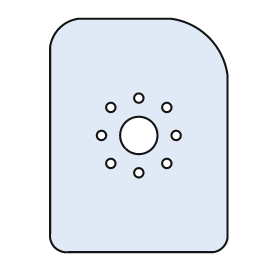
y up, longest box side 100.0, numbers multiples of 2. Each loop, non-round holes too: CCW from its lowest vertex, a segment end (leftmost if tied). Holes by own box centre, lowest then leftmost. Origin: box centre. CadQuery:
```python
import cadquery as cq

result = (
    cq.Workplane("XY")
    .moveTo(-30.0, -50.0)
    .lineTo(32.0, -50.0)
    .threePointArc((36.0, -48.0), (38.0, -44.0))
    .lineTo(38.0, 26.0)
    .threePointArc((30.0, 42.0), (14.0, 50.0))
    .lineTo(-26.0, 50.0)
    .threePointArc((-34.0, 46.0), (-38.0, 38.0))
    .lineTo(-38.0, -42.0)
    .threePointArc((-36.0, -48.0), (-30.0, -50.0))
    .close()
    .moveTo(0.0, -16.0)
    .circle(2.0)
    .moveTo(-12.0, -12.0)
    .circle(2.0)
    .moveTo(12.0, -12.0)
    .circle(2.0)
    .moveTo(-16.0, 0.0)
    .circle(2.0)
    .moveTo(0.0, 0.0)
    .circle(8.0)
    .moveTo(16.0, 0.0)
    .circle(2.0)
    .moveTo(-12.0, 12.0)
    .circle(2.0)
    .moveTo(12.0, 12.0)
    .circle(2.0)
    .moveTo(0.0, 16.0)
    .circle(2.0)
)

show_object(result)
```